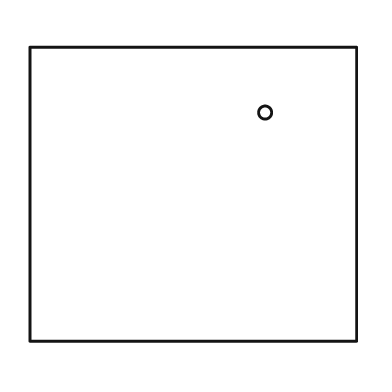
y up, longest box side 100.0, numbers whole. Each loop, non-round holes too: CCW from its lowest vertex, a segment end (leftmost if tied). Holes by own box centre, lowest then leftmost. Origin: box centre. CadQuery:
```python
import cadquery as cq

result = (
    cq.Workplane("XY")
    .moveTo(-50.0, -45.0)
    .lineTo(50.0, -45.0)
    .lineTo(50.0, 45.0)
    .lineTo(-50.0, 45.0)
    .close()
    .moveTo(22.0, 25.0)
    .circle(2.0)
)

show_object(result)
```